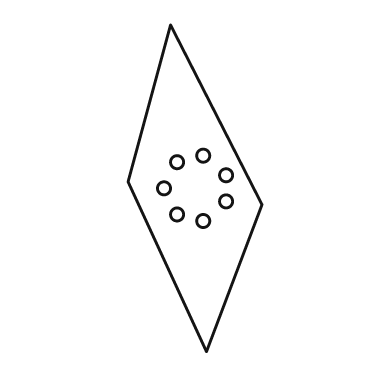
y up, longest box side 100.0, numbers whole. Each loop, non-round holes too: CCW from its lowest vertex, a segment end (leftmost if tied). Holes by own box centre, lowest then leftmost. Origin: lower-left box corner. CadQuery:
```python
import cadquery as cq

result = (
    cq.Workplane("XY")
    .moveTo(24.0, 0.0)
    .lineTo(41.0, 45.0)
    .lineTo(13.0, 100.0)
    .lineTo(0.0, 52.0)
    .close()
    .moveTo(23.0, 40.0)
    .circle(2.0)
    .moveTo(15.0, 42.0)
    .circle(2.0)
    .moveTo(30.0, 46.0)
    .circle(2.0)
    .moveTo(11.0, 50.0)
    .circle(2.0)
    .moveTo(30.0, 54.0)
    .circle(2.0)
    .moveTo(15.0, 58.0)
    .circle(2.0)
    .moveTo(23.0, 60.0)
    .circle(2.0)
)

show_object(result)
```